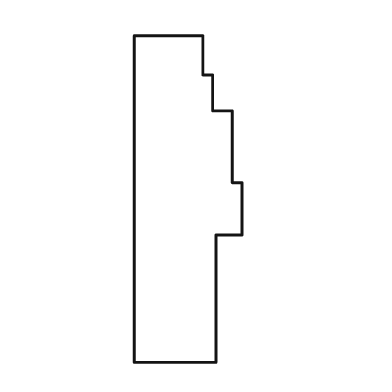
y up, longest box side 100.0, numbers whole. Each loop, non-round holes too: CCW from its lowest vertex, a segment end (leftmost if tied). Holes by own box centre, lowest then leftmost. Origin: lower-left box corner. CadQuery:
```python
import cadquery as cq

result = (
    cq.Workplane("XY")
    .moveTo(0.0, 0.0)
    .lineTo(25.0, 0.0)
    .lineTo(25.0, 39.0)
    .lineTo(33.0, 39.0)
    .lineTo(33.0, 55.0)
    .lineTo(30.0, 55.0)
    .lineTo(30.0, 77.0)
    .lineTo(24.0, 77.0)
    .lineTo(24.0, 88.0)
    .lineTo(21.0, 88.0)
    .lineTo(21.0, 100.0)
    .lineTo(0.0, 100.0)
    .close()
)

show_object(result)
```